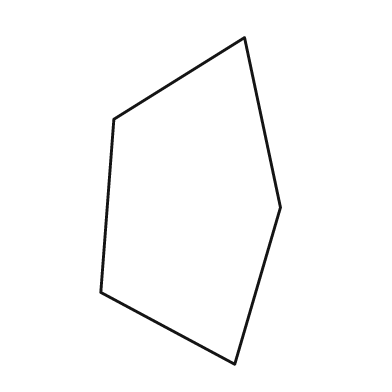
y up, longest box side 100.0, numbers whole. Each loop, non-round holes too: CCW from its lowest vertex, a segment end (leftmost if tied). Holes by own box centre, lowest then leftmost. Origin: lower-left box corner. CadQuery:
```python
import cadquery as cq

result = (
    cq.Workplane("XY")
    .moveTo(41.0, 0.0)
    .lineTo(55.0, 48.0)
    .lineTo(44.0, 100.0)
    .lineTo(4.0, 75.0)
    .lineTo(0.0, 22.0)
    .close()
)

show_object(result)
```